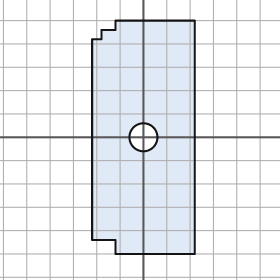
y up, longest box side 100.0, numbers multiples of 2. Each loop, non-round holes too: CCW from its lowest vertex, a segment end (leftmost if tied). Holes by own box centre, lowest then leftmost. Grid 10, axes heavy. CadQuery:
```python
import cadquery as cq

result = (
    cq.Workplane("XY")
    .moveTo(-12.0, -50.0)
    .lineTo(22.0, -50.0)
    .lineTo(22.0, 50.0)
    .lineTo(-12.0, 50.0)
    .lineTo(-12.0, 46.0)
    .lineTo(-18.0, 46.0)
    .lineTo(-18.0, 42.0)
    .lineTo(-22.0, 42.0)
    .lineTo(-22.0, -44.0)
    .lineTo(-12.0, -44.0)
    .close()
    .moveTo(0.0, 0.0)
    .circle(6.0)
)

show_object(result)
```